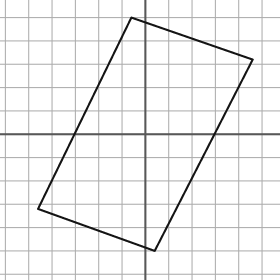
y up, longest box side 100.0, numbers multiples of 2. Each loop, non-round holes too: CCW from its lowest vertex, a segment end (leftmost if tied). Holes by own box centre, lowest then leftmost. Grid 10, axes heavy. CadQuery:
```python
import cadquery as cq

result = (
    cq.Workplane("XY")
    .moveTo(4.0, -50.0)
    .lineTo(46.0, 32.0)
    .lineTo(-6.0, 50.0)
    .lineTo(-46.0, -32.0)
    .close()
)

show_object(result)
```